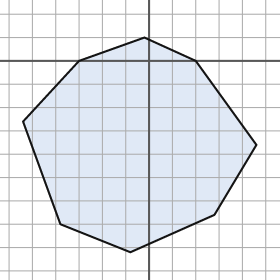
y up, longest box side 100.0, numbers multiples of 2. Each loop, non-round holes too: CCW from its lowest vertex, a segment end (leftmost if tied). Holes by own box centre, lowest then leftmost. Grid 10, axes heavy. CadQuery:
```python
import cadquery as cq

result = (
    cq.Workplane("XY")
    .moveTo(-8.0, -82.0)
    .lineTo(28.0, -66.0)
    .lineTo(46.0, -36.0)
    .lineTo(20.0, 0.0)
    .lineTo(-2.0, 10.0)
    .lineTo(-30.0, 0.0)
    .lineTo(-54.0, -26.0)
    .lineTo(-38.0, -70.0)
    .close()
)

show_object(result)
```